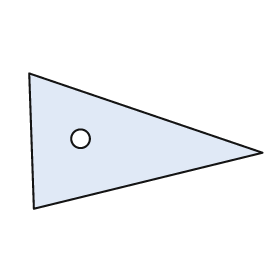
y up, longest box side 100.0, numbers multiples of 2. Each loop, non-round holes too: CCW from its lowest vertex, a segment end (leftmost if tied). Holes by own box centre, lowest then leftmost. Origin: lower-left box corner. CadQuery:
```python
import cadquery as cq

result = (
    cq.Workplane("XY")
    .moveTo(2.0, 0.0)
    .lineTo(100.0, 24.0)
    .lineTo(0.0, 58.0)
    .close()
    .moveTo(22.0, 30.0)
    .circle(4.0)
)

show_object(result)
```